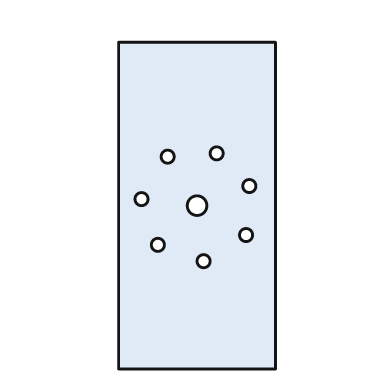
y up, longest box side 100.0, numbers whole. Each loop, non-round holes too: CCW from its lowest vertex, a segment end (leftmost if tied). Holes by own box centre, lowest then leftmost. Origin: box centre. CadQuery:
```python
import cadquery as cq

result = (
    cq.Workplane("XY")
    .moveTo(-24.0, -50.0)
    .lineTo(24.0, -50.0)
    .lineTo(24.0, 50.0)
    .lineTo(-24.0, 50.0)
    .close()
    .moveTo(2.0, -17.0)
    .circle(2.0)
    .moveTo(-12.0, -12.0)
    .circle(2.0)
    .moveTo(15.0, -9.0)
    .circle(2.0)
    .moveTo(0.0, 0.0)
    .circle(3.0)
    .moveTo(-17.0, 2.0)
    .circle(2.0)
    .moveTo(16.0, 6.0)
    .circle(2.0)
    .moveTo(-9.0, 15.0)
    .circle(2.0)
    .moveTo(6.0, 16.0)
    .circle(2.0)
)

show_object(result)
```